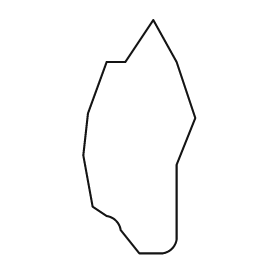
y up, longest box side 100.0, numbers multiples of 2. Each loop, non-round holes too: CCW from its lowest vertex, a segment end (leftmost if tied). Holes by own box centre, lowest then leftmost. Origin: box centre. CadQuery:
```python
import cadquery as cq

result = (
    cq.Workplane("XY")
    .moveTo(0.0, -50.0)
    .lineTo(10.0, -50.0)
    .threePointArc((14.0, -48.0), (16.0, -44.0))
    .lineTo(16.0, -12.0)
    .lineTo(24.0, 8.0)
    .lineTo(16.0, 32.0)
    .lineTo(6.0, 50.0)
    .lineTo(-6.0, 32.0)
    .lineTo(-14.0, 32.0)
    .lineTo(-22.0, 10.0)
    .lineTo(-24.0, -8.0)
    .lineTo(-20.0, -30.0)
    .lineTo(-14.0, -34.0)
    .threePointArc((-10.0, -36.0), (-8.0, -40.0))
    .close()
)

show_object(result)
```